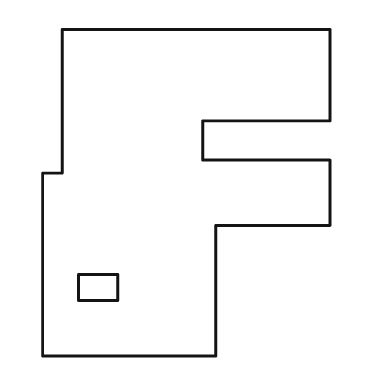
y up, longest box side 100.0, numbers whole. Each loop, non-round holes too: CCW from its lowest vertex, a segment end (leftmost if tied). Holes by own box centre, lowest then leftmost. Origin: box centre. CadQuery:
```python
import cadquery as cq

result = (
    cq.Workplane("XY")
    .moveTo(-44.0, -50.0)
    .lineTo(9.0, -50.0)
    .lineTo(9.0, -10.0)
    .lineTo(44.0, -10.0)
    .lineTo(44.0, 10.0)
    .lineTo(5.0, 10.0)
    .lineTo(5.0, 22.0)
    .lineTo(44.0, 22.0)
    .lineTo(44.0, 50.0)
    .lineTo(-38.0, 50.0)
    .lineTo(-38.0, 6.0)
    .lineTo(-44.0, 6.0)
    .close()
    .moveTo(-33.0, -33.0)
    .lineTo(-21.0, -33.0)
    .lineTo(-21.0, -25.0)
    .lineTo(-33.0, -25.0)
    .close()
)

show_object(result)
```